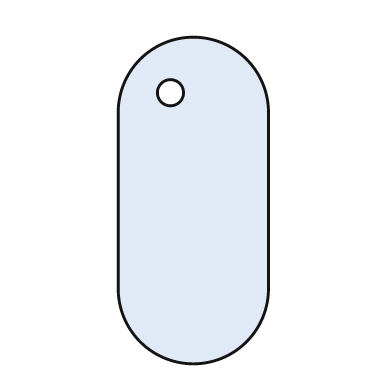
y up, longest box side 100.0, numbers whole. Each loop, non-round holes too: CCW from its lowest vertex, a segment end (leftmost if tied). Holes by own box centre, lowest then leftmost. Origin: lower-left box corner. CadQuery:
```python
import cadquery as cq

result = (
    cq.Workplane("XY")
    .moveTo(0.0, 23.0)
    .threePointArc((23.0, 0.0), (46.0, 23.0))
    .lineTo(46.0, 77.0)
    .threePointArc((23.0, 100.0), (0.0, 77.0))
    .close()
    .moveTo(16.0, 83.0)
    .circle(4.0)
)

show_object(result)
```